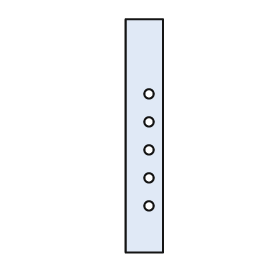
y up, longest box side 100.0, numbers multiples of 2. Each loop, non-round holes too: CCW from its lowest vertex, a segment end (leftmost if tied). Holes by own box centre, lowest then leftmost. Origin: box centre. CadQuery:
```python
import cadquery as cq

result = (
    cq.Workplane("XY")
    .moveTo(-8.0, -50.0)
    .lineTo(8.0, -50.0)
    .lineTo(8.0, 50.0)
    .lineTo(-8.0, 50.0)
    .close()
    .moveTo(2.0, -30.0)
    .circle(2.0)
    .moveTo(2.0, -18.0)
    .circle(2.0)
    .moveTo(2.0, -6.0)
    .circle(2.0)
    .moveTo(2.0, 6.0)
    .circle(2.0)
    .moveTo(2.0, 18.0)
    .circle(2.0)
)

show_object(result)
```